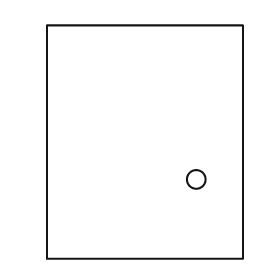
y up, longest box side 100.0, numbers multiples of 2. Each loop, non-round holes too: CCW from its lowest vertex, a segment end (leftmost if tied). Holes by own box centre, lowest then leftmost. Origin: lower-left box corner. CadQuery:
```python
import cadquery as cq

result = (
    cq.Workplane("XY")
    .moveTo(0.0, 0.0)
    .lineTo(84.0, 0.0)
    .lineTo(84.0, 100.0)
    .lineTo(0.0, 100.0)
    .close()
    .moveTo(64.0, 34.0)
    .circle(4.0)
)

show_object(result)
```